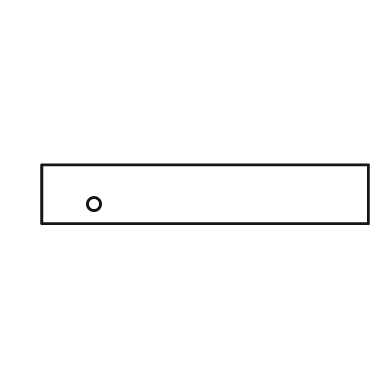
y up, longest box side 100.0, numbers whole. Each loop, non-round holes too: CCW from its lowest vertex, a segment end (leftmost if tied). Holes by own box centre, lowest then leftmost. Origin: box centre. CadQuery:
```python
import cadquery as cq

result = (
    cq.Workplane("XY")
    .moveTo(-50.0, -9.0)
    .lineTo(50.0, -9.0)
    .lineTo(50.0, 9.0)
    .lineTo(-50.0, 9.0)
    .close()
    .moveTo(-34.0, -3.0)
    .circle(2.0)
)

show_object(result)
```